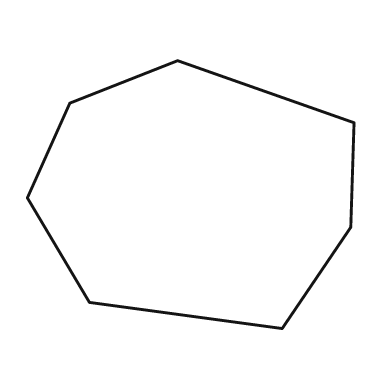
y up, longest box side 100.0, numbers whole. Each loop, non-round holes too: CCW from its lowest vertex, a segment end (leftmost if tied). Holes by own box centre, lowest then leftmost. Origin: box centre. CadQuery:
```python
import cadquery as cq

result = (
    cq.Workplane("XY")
    .moveTo(28.0, -41.0)
    .lineTo(49.0, -10.0)
    .lineTo(50.0, 22.0)
    .lineTo(-4.0, 41.0)
    .lineTo(-37.0, 28.0)
    .lineTo(-50.0, -1.0)
    .lineTo(-31.0, -33.0)
    .close()
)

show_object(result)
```